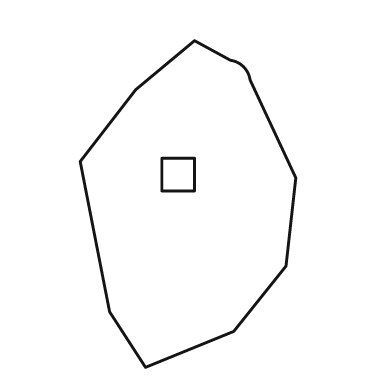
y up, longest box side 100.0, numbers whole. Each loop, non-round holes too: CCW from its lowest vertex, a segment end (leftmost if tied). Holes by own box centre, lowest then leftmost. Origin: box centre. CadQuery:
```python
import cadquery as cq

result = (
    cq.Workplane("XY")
    .moveTo(-13.0, -50.0)
    .lineTo(14.0, -39.0)
    .lineTo(30.0, -19.0)
    .lineTo(33.0, 8.0)
    .lineTo(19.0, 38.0)
    .threePointArc((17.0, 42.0), (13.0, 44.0))
    .lineTo(2.0, 50.0)
    .lineTo(-16.0, 35.0)
    .lineTo(-33.0, 13.0)
    .lineTo(-24.0, -33.0)
    .close()
    .moveTo(-8.0, 4.0)
    .lineTo(2.0, 4.0)
    .lineTo(2.0, 14.0)
    .lineTo(-8.0, 14.0)
    .close()
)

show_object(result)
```